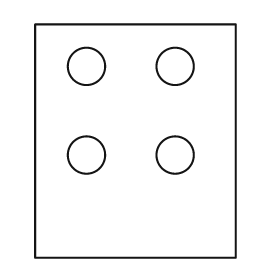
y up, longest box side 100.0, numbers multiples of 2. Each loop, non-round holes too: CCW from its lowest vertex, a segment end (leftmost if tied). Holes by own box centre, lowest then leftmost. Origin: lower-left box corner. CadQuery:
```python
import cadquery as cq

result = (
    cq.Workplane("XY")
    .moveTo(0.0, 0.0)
    .lineTo(86.0, 0.0)
    .lineTo(86.0, 100.0)
    .lineTo(0.0, 100.0)
    .close()
    .moveTo(22.0, 44.0)
    .circle(8.0)
    .moveTo(60.0, 44.0)
    .circle(8.0)
    .moveTo(22.0, 82.0)
    .circle(8.0)
    .moveTo(60.0, 82.0)
    .circle(8.0)
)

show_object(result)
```